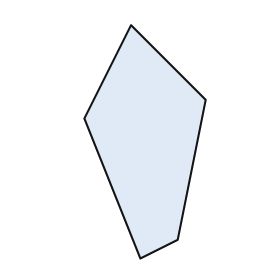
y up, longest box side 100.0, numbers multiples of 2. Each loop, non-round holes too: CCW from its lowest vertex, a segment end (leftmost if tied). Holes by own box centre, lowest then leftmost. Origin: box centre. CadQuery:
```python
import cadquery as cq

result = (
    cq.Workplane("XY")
    .moveTo(-2.0, -50.0)
    .lineTo(14.0, -42.0)
    .lineTo(26.0, 18.0)
    .lineTo(-6.0, 50.0)
    .lineTo(-26.0, 10.0)
    .close()
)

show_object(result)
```